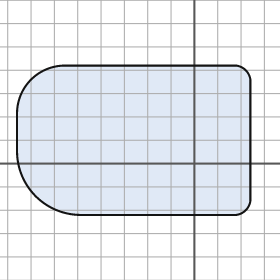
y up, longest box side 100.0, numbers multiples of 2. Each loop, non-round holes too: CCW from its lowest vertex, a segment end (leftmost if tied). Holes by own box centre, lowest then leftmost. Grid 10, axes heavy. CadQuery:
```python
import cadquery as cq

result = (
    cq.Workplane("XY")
    .moveTo(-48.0, -22.0)
    .lineTo(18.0, -22.0)
    .threePointArc((22.0, -20.0), (24.0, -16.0))
    .lineTo(24.0, 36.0)
    .threePointArc((22.0, 40.0), (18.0, 42.0))
    .lineTo(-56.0, 42.0)
    .threePointArc((-70.0, 36.0), (-76.0, 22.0))
    .lineTo(-76.0, 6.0)
    .threePointArc((-68.0, -14.0), (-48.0, -22.0))
    .close()
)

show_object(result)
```